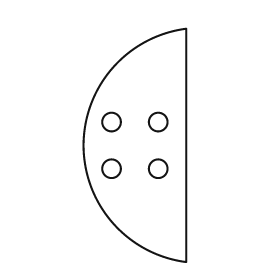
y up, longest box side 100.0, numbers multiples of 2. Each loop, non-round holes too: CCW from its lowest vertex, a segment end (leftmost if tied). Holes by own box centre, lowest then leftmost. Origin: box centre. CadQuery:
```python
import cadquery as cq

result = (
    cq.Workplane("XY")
    .moveTo(22.0, -50.0)
    .lineTo(22.0, 50.0)
    .threePointArc((-22.0, 0.0), (22.0, -50.0))
    .close()
    .moveTo(-10.0, -10.0)
    .circle(4.0)
    .moveTo(10.0, -10.0)
    .circle(4.0)
    .moveTo(-10.0, 10.0)
    .circle(4.0)
    .moveTo(10.0, 10.0)
    .circle(4.0)
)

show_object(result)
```